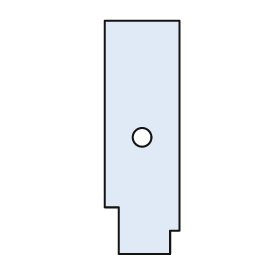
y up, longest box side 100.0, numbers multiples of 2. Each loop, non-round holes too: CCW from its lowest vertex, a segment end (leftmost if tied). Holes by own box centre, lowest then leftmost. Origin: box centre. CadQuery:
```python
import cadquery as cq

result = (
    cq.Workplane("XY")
    .moveTo(-10.0, -50.0)
    .lineTo(12.0, -50.0)
    .lineTo(12.0, -40.0)
    .lineTo(16.0, -40.0)
    .lineTo(16.0, 50.0)
    .lineTo(-16.0, 50.0)
    .lineTo(-16.0, -30.0)
    .lineTo(-10.0, -30.0)
    .close()
    .moveTo(0.0, 0.0)
    .circle(4.0)
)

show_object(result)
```